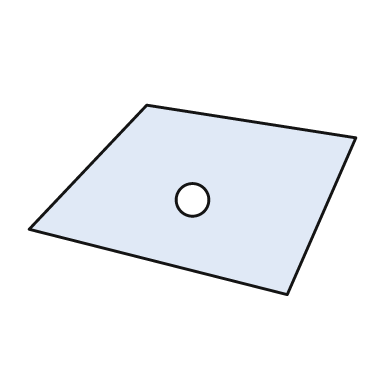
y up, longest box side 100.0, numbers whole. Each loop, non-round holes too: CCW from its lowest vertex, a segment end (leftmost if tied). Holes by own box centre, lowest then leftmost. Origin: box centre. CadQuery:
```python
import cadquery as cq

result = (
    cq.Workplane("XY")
    .moveTo(29.0, -29.0)
    .lineTo(50.0, 19.0)
    .lineTo(-14.0, 29.0)
    .lineTo(-50.0, -9.0)
    .close()
    .moveTo(0.0, 0.0)
    .circle(5.0)
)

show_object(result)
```